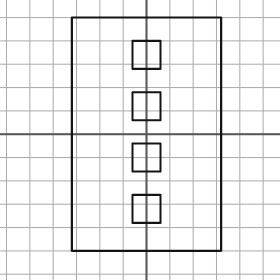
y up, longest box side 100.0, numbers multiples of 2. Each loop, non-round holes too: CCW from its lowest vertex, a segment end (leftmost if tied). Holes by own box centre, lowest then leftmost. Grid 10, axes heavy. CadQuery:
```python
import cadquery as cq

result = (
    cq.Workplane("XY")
    .moveTo(-32.0, -50.0)
    .lineTo(32.0, -50.0)
    .lineTo(32.0, 50.0)
    .lineTo(-32.0, 50.0)
    .close()
    .moveTo(-6.0, -38.0)
    .lineTo(6.0, -38.0)
    .lineTo(6.0, -26.0)
    .lineTo(-6.0, -26.0)
    .close()
    .moveTo(-6.0, -16.0)
    .lineTo(6.0, -16.0)
    .lineTo(6.0, -4.0)
    .lineTo(-6.0, -4.0)
    .close()
    .moveTo(-6.0, 6.0)
    .lineTo(6.0, 6.0)
    .lineTo(6.0, 18.0)
    .lineTo(-6.0, 18.0)
    .close()
    .moveTo(-6.0, 28.0)
    .lineTo(6.0, 28.0)
    .lineTo(6.0, 40.0)
    .lineTo(-6.0, 40.0)
    .close()
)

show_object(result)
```